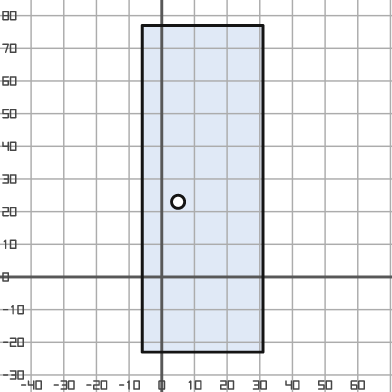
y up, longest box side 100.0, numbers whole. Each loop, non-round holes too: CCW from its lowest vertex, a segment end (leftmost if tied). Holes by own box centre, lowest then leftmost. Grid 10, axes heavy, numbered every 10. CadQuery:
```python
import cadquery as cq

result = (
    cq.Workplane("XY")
    .moveTo(-6.0, -23.0)
    .lineTo(31.0, -23.0)
    .lineTo(31.0, 77.0)
    .lineTo(-6.0, 77.0)
    .close()
    .moveTo(5.0, 23.0)
    .circle(2.0)
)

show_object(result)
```